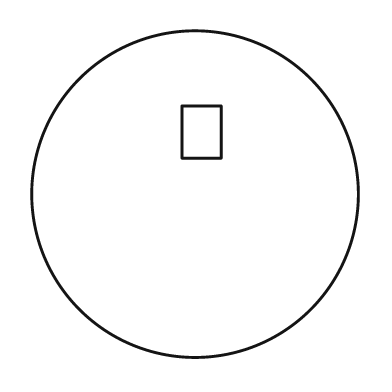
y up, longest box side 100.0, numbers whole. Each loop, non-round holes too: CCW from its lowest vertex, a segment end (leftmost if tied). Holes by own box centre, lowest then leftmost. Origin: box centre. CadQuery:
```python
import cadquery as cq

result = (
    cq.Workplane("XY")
    .moveTo(0.0, 0.0)
    .circle(50.0)
    .moveTo(-4.0, 11.0)
    .lineTo(8.0, 11.0)
    .lineTo(8.0, 27.0)
    .lineTo(-4.0, 27.0)
    .close()
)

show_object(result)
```